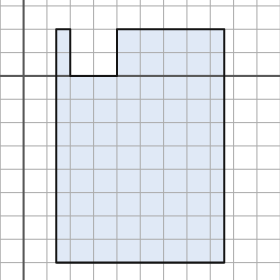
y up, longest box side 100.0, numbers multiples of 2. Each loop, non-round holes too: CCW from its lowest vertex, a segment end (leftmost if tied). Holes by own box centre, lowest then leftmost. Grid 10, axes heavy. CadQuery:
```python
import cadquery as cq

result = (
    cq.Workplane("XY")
    .moveTo(14.0, -80.0)
    .lineTo(86.0, -80.0)
    .lineTo(86.0, 20.0)
    .lineTo(40.0, 20.0)
    .lineTo(40.0, 0.0)
    .lineTo(20.0, 0.0)
    .lineTo(20.0, 20.0)
    .lineTo(14.0, 20.0)
    .close()
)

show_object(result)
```